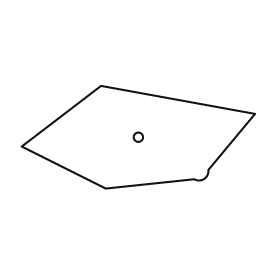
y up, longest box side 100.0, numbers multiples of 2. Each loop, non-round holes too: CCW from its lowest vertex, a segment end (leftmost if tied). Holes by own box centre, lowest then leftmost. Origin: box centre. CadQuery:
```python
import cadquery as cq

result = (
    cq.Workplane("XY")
    .moveTo(-14.0, -22.0)
    .lineTo(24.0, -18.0)
    .threePointArc((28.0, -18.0), (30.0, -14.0))
    .lineTo(50.0, 10.0)
    .lineTo(-16.0, 22.0)
    .lineTo(-50.0, -4.0)
    .close()
    .moveTo(0.0, 0.0)
    .circle(2.0)
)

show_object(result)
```